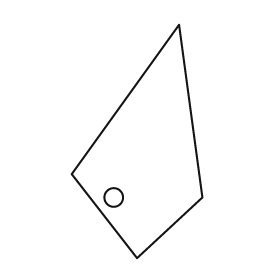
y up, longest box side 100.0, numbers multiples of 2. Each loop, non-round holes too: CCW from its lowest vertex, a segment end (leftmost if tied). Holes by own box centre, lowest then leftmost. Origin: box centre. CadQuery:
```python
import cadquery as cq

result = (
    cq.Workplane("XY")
    .moveTo(0.0, -50.0)
    .lineTo(28.0, -24.0)
    .lineTo(18.0, 50.0)
    .lineTo(-28.0, -14.0)
    .close()
    .moveTo(-10.0, -24.0)
    .circle(4.0)
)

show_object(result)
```